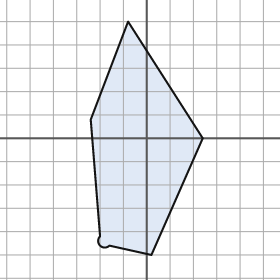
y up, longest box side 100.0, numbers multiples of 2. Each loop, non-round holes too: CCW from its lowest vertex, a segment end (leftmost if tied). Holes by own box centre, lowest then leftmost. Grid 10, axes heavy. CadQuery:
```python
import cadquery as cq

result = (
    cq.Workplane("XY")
    .moveTo(2.0, -50.0)
    .lineTo(24.0, 0.0)
    .lineTo(-8.0, 50.0)
    .lineTo(-24.0, 8.0)
    .lineTo(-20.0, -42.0)
    .threePointArc((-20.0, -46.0), (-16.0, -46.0))
    .close()
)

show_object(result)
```